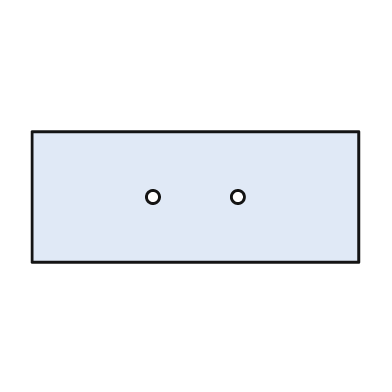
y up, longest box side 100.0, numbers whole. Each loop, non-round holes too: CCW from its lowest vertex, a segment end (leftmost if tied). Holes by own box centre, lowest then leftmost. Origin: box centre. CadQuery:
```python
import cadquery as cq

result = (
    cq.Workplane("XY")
    .moveTo(-50.0, -20.0)
    .lineTo(50.0, -20.0)
    .lineTo(50.0, 20.0)
    .lineTo(-50.0, 20.0)
    .close()
    .moveTo(-13.0, 0.0)
    .circle(2.0)
    .moveTo(13.0, 0.0)
    .circle(2.0)
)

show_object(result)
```